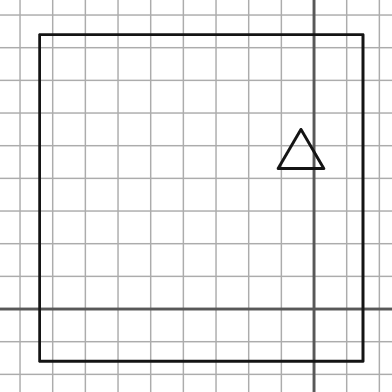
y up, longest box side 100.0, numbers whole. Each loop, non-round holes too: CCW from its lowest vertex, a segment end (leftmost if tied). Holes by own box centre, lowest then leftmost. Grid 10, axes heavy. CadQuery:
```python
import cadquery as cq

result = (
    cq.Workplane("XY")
    .moveTo(-84.0, -16.0)
    .lineTo(15.0, -16.0)
    .lineTo(15.0, 84.0)
    .lineTo(-84.0, 84.0)
    .close()
    .moveTo(-11.0, 43.0)
    .lineTo(3.0, 43.0)
    .lineTo(-4.0, 55.0)
    .close()
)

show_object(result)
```